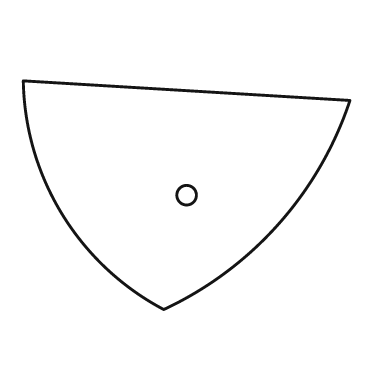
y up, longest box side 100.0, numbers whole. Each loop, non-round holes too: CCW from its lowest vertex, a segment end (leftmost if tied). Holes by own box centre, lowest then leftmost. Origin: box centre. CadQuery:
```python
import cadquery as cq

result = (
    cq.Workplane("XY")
    .moveTo(-7.0, -35.0)
    .threePointArc((28.0, -9.0), (50.0, 29.0))
    .lineTo(-50.0, 35.0)
    .threePointArc((-38.0, -6.0), (-7.0, -35.0))
    .close()
    .moveTo(0.0, 0.0)
    .circle(3.0)
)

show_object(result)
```